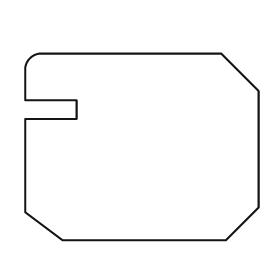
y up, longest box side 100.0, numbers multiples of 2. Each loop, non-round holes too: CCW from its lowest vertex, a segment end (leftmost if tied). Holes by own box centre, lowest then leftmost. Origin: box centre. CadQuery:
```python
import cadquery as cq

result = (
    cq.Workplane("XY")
    .moveTo(-34.0, -40.0)
    .lineTo(36.0, -40.0)
    .lineTo(50.0, -26.0)
    .lineTo(50.0, 24.0)
    .lineTo(34.0, 40.0)
    .lineTo(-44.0, 40.0)
    .threePointArc((-48.0, 38.0), (-50.0, 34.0))
    .lineTo(-50.0, 20.0)
    .lineTo(-28.0, 20.0)
    .lineTo(-28.0, 12.0)
    .lineTo(-50.0, 12.0)
    .lineTo(-50.0, -28.0)
    .close()
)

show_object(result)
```